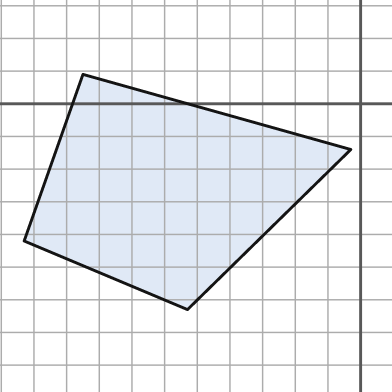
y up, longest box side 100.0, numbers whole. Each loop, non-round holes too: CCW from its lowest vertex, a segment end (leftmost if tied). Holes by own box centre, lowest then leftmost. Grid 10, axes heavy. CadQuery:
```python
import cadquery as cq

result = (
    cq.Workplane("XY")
    .moveTo(-53.0, -63.0)
    .lineTo(-3.0, -14.0)
    .lineTo(-85.0, 9.0)
    .lineTo(-103.0, -42.0)
    .close()
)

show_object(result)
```